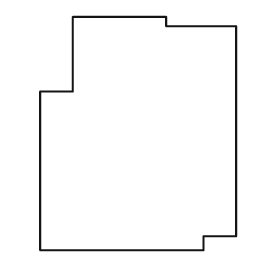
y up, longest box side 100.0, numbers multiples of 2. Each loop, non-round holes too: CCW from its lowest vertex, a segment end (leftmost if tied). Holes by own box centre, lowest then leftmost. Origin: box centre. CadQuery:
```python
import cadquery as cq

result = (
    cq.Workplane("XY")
    .moveTo(-42.0, -50.0)
    .lineTo(28.0, -50.0)
    .lineTo(28.0, -44.0)
    .lineTo(42.0, -44.0)
    .lineTo(42.0, 46.0)
    .lineTo(12.0, 46.0)
    .lineTo(12.0, 50.0)
    .lineTo(-28.0, 50.0)
    .lineTo(-28.0, 18.0)
    .lineTo(-42.0, 18.0)
    .close()
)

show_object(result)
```